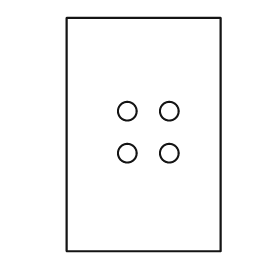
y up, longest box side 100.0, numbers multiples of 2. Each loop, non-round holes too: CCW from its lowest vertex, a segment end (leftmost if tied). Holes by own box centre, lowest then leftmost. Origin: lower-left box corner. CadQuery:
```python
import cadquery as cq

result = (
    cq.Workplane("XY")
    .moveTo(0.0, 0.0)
    .lineTo(66.0, 0.0)
    .lineTo(66.0, 100.0)
    .lineTo(0.0, 100.0)
    .close()
    .moveTo(26.0, 42.0)
    .circle(4.0)
    .moveTo(44.0, 42.0)
    .circle(4.0)
    .moveTo(26.0, 60.0)
    .circle(4.0)
    .moveTo(44.0, 60.0)
    .circle(4.0)
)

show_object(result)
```